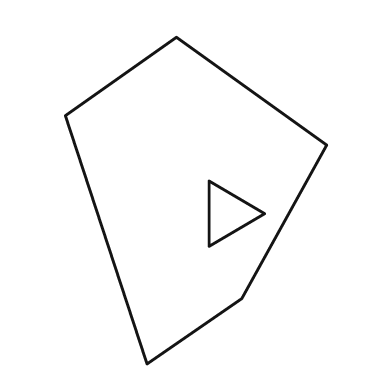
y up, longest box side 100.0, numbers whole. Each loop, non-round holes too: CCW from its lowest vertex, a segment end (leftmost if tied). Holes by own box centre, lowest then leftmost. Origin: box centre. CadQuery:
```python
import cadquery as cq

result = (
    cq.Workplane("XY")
    .moveTo(-15.0, -50.0)
    .lineTo(14.0, -30.0)
    .lineTo(40.0, 17.0)
    .lineTo(-6.0, 50.0)
    .lineTo(-40.0, 26.0)
    .close()
    .moveTo(4.0, -14.0)
    .lineTo(21.0, -4.0)
    .lineTo(4.0, 6.0)
    .close()
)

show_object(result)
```